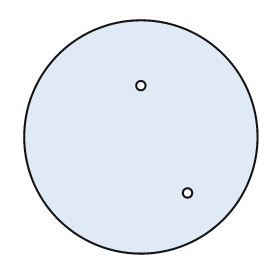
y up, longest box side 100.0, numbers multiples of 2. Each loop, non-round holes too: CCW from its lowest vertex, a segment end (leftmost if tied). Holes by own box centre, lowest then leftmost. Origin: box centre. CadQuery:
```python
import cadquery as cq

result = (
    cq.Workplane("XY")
    .moveTo(0.0, 0.0)
    .circle(50.0)
    .moveTo(20.0, -24.0)
    .circle(2.0)
    .moveTo(0.0, 22.0)
    .circle(2.0)
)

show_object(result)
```